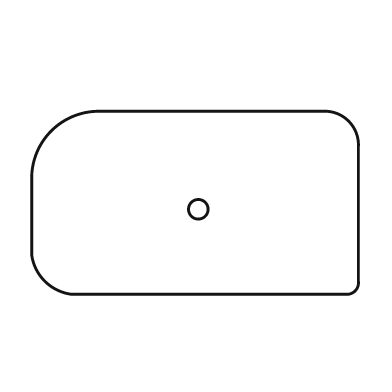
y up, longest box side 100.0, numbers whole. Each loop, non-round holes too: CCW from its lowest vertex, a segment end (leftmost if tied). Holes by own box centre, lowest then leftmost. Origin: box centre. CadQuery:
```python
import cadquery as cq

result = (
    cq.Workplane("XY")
    .moveTo(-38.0, -28.0)
    .lineTo(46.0, -28.0)
    .threePointArc((49.0, -27.0), (50.0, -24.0))
    .lineTo(50.0, 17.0)
    .threePointArc((47.0, 25.0), (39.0, 28.0))
    .lineTo(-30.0, 28.0)
    .threePointArc((-44.0, 22.0), (-50.0, 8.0))
    .lineTo(-50.0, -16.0)
    .threePointArc((-46.0, -24.0), (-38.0, -28.0))
    .close()
    .moveTo(1.0, -2.0)
    .circle(3.0)
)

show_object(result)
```